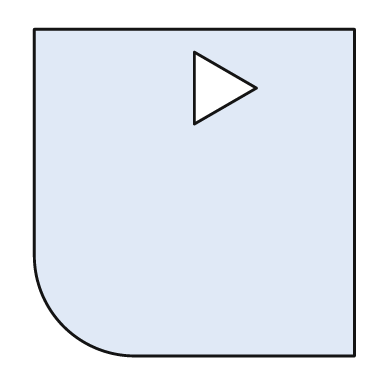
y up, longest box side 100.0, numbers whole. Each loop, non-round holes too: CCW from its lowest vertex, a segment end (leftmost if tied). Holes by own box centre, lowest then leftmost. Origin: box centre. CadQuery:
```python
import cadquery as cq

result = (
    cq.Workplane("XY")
    .moveTo(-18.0, -50.0)
    .lineTo(49.0, -50.0)
    .lineTo(49.0, 50.0)
    .lineTo(-49.0, 50.0)
    .lineTo(-49.0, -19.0)
    .threePointArc((-40.0, -41.0), (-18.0, -50.0))
    .close()
    .moveTo(0.0, 21.0)
    .lineTo(19.0, 32.0)
    .lineTo(0.0, 43.0)
    .close()
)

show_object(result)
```